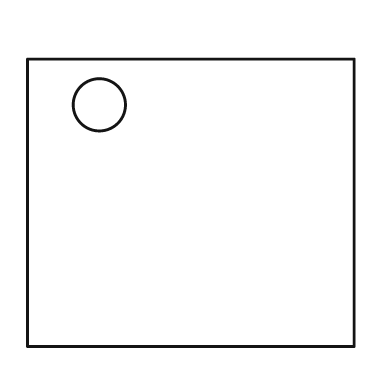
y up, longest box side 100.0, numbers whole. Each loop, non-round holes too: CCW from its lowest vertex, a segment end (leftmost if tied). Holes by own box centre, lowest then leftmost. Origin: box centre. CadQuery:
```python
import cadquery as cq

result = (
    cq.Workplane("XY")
    .moveTo(-50.0, -44.0)
    .lineTo(50.0, -44.0)
    .lineTo(50.0, 44.0)
    .lineTo(-50.0, 44.0)
    .close()
    .moveTo(-28.0, 30.0)
    .circle(8.0)
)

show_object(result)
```